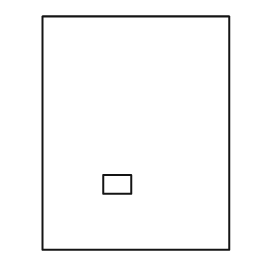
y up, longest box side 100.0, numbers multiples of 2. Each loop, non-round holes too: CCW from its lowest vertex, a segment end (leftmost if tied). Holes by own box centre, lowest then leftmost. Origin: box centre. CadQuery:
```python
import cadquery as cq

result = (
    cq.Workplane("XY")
    .moveTo(-40.0, -50.0)
    .lineTo(40.0, -50.0)
    .lineTo(40.0, 50.0)
    .lineTo(-40.0, 50.0)
    .close()
    .moveTo(-14.0, -26.0)
    .lineTo(-2.0, -26.0)
    .lineTo(-2.0, -18.0)
    .lineTo(-14.0, -18.0)
    .close()
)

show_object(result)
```